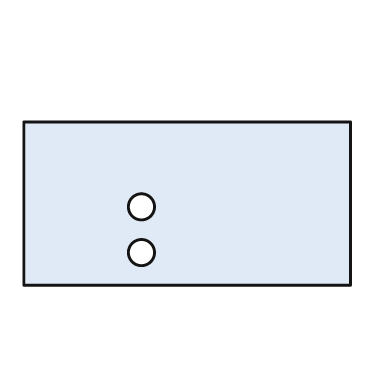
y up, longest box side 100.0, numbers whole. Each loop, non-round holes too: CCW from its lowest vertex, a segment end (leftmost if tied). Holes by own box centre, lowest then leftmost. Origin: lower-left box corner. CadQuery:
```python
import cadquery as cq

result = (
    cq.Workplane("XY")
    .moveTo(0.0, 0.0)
    .lineTo(100.0, 0.0)
    .lineTo(100.0, 50.0)
    .lineTo(0.0, 50.0)
    .close()
    .moveTo(36.0, 10.0)
    .circle(4.0)
    .moveTo(36.0, 24.0)
    .circle(4.0)
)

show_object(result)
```